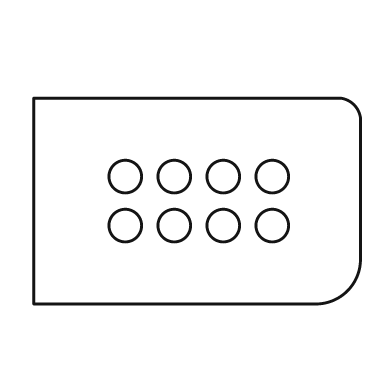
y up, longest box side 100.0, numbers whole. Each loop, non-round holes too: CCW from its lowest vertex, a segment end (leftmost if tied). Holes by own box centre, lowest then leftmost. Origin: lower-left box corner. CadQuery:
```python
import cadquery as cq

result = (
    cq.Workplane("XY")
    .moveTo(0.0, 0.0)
    .lineTo(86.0, 0.0)
    .threePointArc((96.0, 4.0), (100.0, 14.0))
    .lineTo(100.0, 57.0)
    .threePointArc((98.0, 61.0), (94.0, 63.0))
    .lineTo(0.0, 63.0)
    .close()
    .moveTo(28.0, 24.0)
    .circle(5.0)
    .moveTo(43.0, 24.0)
    .circle(5.0)
    .moveTo(58.0, 24.0)
    .circle(5.0)
    .moveTo(73.0, 24.0)
    .circle(5.0)
    .moveTo(28.0, 39.0)
    .circle(5.0)
    .moveTo(43.0, 39.0)
    .circle(5.0)
    .moveTo(58.0, 39.0)
    .circle(5.0)
    .moveTo(73.0, 39.0)
    .circle(5.0)
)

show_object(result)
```